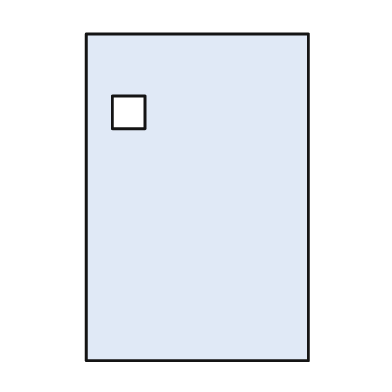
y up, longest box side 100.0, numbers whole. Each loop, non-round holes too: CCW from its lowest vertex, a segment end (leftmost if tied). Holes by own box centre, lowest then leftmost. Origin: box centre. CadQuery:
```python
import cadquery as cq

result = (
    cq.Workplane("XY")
    .moveTo(-34.0, -50.0)
    .lineTo(34.0, -50.0)
    .lineTo(34.0, 50.0)
    .lineTo(-34.0, 50.0)
    .close()
    .moveTo(-26.0, 21.0)
    .lineTo(-16.0, 21.0)
    .lineTo(-16.0, 31.0)
    .lineTo(-26.0, 31.0)
    .close()
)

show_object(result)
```